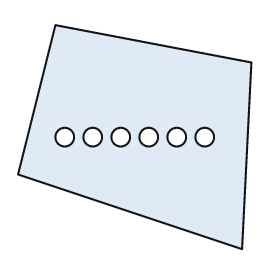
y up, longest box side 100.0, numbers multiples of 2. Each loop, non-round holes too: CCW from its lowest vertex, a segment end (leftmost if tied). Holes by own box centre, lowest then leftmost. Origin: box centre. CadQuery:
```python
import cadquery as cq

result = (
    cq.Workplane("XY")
    .moveTo(46.0, -48.0)
    .lineTo(50.0, 32.0)
    .lineTo(-34.0, 48.0)
    .lineTo(-50.0, -16.0)
    .close()
    .moveTo(-30.0, 0.0)
    .circle(4.0)
    .moveTo(-18.0, 0.0)
    .circle(4.0)
    .moveTo(-6.0, 0.0)
    .circle(4.0)
    .moveTo(6.0, 0.0)
    .circle(4.0)
    .moveTo(18.0, 0.0)
    .circle(4.0)
    .moveTo(30.0, 0.0)
    .circle(4.0)
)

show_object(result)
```